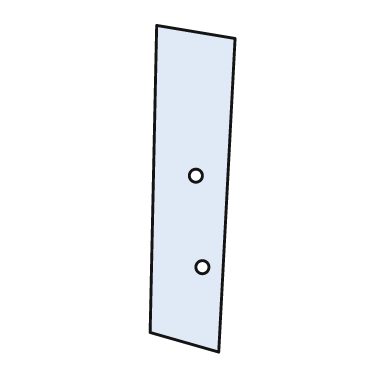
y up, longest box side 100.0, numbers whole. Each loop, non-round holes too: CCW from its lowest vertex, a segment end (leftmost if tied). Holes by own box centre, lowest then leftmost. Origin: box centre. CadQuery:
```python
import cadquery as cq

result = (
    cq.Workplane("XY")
    .moveTo(8.0, -50.0)
    .lineTo(13.0, 46.0)
    .lineTo(-11.0, 50.0)
    .lineTo(-13.0, -44.0)
    .close()
    .moveTo(3.0, -24.0)
    .circle(2.0)
    .moveTo(1.0, 4.0)
    .circle(2.0)
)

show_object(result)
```